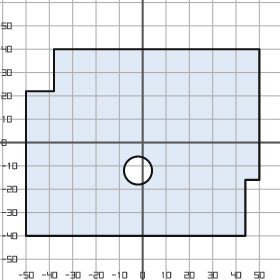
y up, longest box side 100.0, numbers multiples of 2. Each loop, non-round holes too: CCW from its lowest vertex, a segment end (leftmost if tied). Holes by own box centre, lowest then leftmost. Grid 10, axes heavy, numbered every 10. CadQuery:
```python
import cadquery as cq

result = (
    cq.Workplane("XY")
    .moveTo(-50.0, -40.0)
    .lineTo(44.0, -40.0)
    .lineTo(44.0, -16.0)
    .lineTo(50.0, -16.0)
    .lineTo(50.0, 40.0)
    .lineTo(-38.0, 40.0)
    .lineTo(-38.0, 22.0)
    .lineTo(-50.0, 22.0)
    .close()
    .moveTo(-2.0, -12.0)
    .circle(6.0)
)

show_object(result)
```